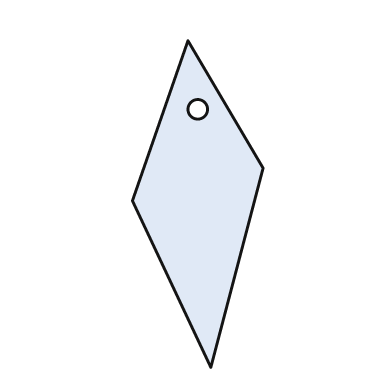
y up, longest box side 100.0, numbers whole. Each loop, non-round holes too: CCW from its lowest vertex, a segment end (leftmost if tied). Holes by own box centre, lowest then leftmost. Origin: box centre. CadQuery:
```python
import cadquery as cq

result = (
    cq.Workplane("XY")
    .moveTo(4.0, -50.0)
    .lineTo(20.0, 11.0)
    .lineTo(-3.0, 50.0)
    .lineTo(-20.0, 1.0)
    .close()
    .moveTo(0.0, 29.0)
    .circle(3.0)
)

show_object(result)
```